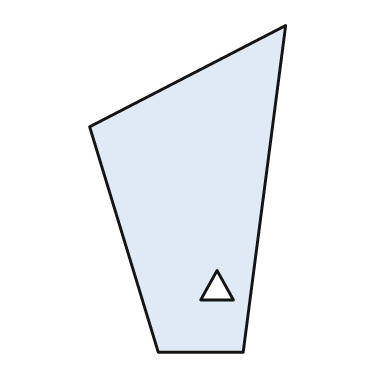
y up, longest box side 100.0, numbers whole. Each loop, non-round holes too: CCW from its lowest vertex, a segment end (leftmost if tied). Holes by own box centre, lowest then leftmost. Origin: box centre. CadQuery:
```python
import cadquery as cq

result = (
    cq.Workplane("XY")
    .moveTo(-9.0, -50.0)
    .lineTo(17.0, -50.0)
    .lineTo(30.0, 50.0)
    .lineTo(-30.0, 19.0)
    .close()
    .moveTo(4.0, -34.0)
    .lineTo(14.0, -34.0)
    .lineTo(9.0, -25.0)
    .close()
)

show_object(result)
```